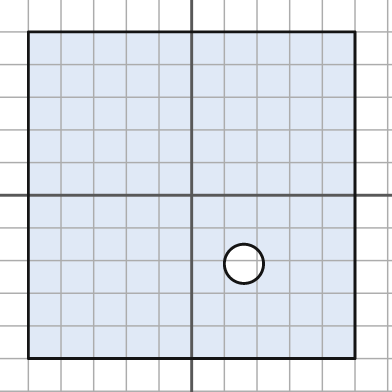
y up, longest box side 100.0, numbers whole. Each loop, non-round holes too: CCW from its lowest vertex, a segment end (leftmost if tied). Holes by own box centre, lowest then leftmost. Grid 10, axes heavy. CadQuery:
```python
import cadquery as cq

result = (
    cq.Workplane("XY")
    .moveTo(-50.0, -50.0)
    .lineTo(50.0, -50.0)
    .lineTo(50.0, 50.0)
    .lineTo(-50.0, 50.0)
    .close()
    .moveTo(16.0, -21.0)
    .circle(6.0)
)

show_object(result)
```